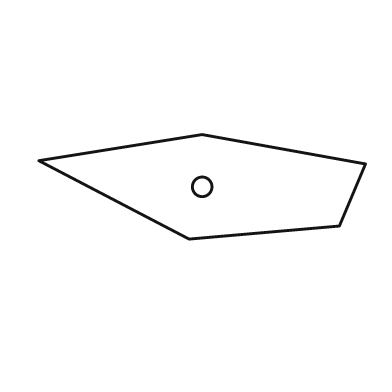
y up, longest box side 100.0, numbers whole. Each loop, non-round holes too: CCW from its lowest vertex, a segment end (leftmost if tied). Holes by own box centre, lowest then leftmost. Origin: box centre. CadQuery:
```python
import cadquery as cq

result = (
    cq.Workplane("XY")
    .moveTo(-4.0, -16.0)
    .lineTo(42.0, -12.0)
    .lineTo(50.0, 7.0)
    .lineTo(0.0, 16.0)
    .lineTo(-50.0, 8.0)
    .close()
    .moveTo(0.0, 0.0)
    .circle(3.0)
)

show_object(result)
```